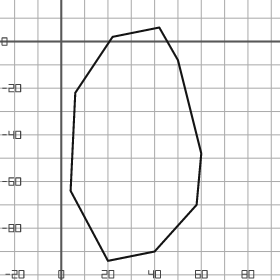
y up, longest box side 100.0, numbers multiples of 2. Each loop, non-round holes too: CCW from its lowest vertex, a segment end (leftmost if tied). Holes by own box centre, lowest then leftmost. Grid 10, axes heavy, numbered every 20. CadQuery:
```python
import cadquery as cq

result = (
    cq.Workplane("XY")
    .moveTo(20.0, -94.0)
    .lineTo(40.0, -90.0)
    .lineTo(58.0, -70.0)
    .lineTo(60.0, -48.0)
    .lineTo(50.0, -8.0)
    .lineTo(42.0, 6.0)
    .lineTo(22.0, 2.0)
    .lineTo(6.0, -22.0)
    .lineTo(4.0, -64.0)
    .close()
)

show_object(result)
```